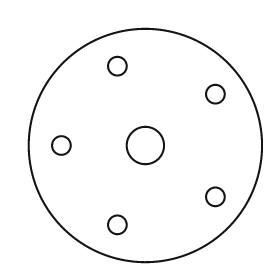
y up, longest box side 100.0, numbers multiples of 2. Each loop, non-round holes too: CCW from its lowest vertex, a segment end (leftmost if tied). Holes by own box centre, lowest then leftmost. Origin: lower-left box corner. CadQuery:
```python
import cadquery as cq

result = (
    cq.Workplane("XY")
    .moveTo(50.0, 50.0)
    .circle(50.0)
    .moveTo(38.0, 16.0)
    .circle(4.0)
    .moveTo(80.0, 28.0)
    .circle(4.0)
    .moveTo(14.0, 50.0)
    .circle(4.0)
    .moveTo(50.0, 50.0)
    .circle(8.0)
    .moveTo(80.0, 72.0)
    .circle(4.0)
    .moveTo(38.0, 84.0)
    .circle(4.0)
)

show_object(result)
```